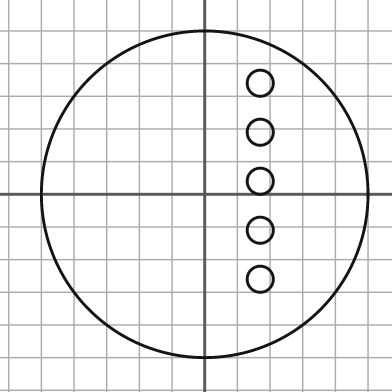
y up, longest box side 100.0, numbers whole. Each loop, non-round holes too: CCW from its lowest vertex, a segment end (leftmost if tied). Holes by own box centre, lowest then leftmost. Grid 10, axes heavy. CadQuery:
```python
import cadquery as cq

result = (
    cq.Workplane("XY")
    .moveTo(0.0, 0.0)
    .circle(50.0)
    .moveTo(17.0, -26.0)
    .circle(4.0)
    .moveTo(17.0, -11.0)
    .circle(4.0)
    .moveTo(17.0, 4.0)
    .circle(4.0)
    .moveTo(17.0, 19.0)
    .circle(4.0)
    .moveTo(17.0, 34.0)
    .circle(4.0)
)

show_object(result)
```